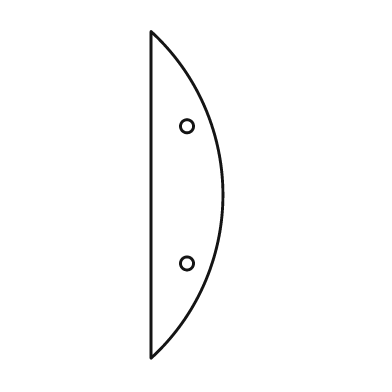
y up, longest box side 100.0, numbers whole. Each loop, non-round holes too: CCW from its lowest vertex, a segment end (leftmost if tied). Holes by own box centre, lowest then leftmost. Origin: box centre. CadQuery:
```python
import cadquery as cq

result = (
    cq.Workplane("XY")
    .moveTo(-11.0, -50.0)
    .threePointArc((11.0, 0.0), (-11.0, 50.0))
    .close()
    .moveTo(0.0, -21.0)
    .circle(2.0)
    .moveTo(0.0, 21.0)
    .circle(2.0)
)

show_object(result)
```